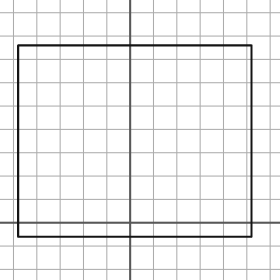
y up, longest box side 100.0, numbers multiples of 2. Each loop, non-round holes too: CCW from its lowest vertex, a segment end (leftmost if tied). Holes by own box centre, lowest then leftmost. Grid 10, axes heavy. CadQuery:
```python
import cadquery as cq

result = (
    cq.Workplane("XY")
    .moveTo(-48.0, -6.0)
    .lineTo(52.0, -6.0)
    .lineTo(52.0, 76.0)
    .lineTo(-48.0, 76.0)
    .close()
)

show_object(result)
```